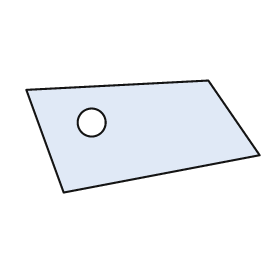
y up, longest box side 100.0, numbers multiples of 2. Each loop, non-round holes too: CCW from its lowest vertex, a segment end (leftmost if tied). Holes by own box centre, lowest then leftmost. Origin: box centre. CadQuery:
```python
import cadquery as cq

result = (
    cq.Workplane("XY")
    .moveTo(-34.0, -24.0)
    .lineTo(50.0, -8.0)
    .lineTo(28.0, 24.0)
    .lineTo(-50.0, 20.0)
    .close()
    .moveTo(-22.0, 6.0)
    .circle(6.0)
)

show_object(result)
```